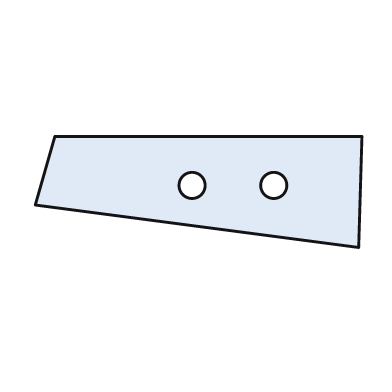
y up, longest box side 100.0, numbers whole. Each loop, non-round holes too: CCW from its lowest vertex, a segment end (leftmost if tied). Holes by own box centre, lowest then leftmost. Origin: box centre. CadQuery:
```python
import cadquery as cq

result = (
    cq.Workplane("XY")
    .moveTo(49.0, -17.0)
    .lineTo(50.0, 17.0)
    .lineTo(-44.0, 17.0)
    .lineTo(-50.0, -4.0)
    .close()
    .moveTo(-2.0, 2.0)
    .circle(4.0)
    .moveTo(23.0, 2.0)
    .circle(4.0)
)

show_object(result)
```